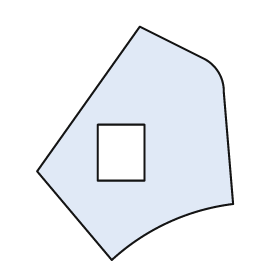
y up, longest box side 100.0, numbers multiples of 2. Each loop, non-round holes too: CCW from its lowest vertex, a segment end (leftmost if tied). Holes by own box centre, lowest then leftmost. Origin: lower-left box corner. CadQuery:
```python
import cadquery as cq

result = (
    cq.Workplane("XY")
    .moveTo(32.0, 0.0)
    .threePointArc((56.0, 16.0), (84.0, 24.0))
    .lineTo(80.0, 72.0)
    .threePointArc((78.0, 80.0), (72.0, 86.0))
    .lineTo(44.0, 100.0)
    .lineTo(0.0, 38.0)
    .close()
    .moveTo(26.0, 34.0)
    .lineTo(46.0, 34.0)
    .lineTo(46.0, 58.0)
    .lineTo(26.0, 58.0)
    .close()
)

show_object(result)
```